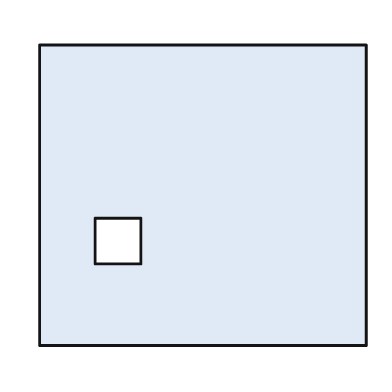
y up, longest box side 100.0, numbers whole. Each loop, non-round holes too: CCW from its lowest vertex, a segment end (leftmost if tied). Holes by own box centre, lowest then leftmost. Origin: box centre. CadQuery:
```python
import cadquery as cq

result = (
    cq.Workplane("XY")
    .moveTo(-50.0, -46.0)
    .lineTo(50.0, -46.0)
    .lineTo(50.0, 46.0)
    .lineTo(-50.0, 46.0)
    .close()
    .moveTo(-33.0, -21.0)
    .lineTo(-19.0, -21.0)
    .lineTo(-19.0, -7.0)
    .lineTo(-33.0, -7.0)
    .close()
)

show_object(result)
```